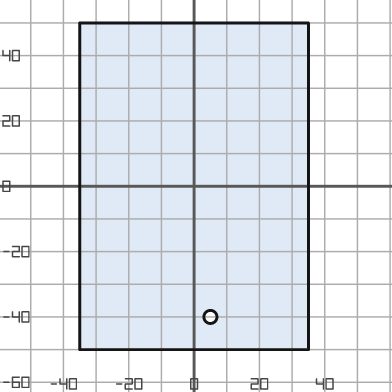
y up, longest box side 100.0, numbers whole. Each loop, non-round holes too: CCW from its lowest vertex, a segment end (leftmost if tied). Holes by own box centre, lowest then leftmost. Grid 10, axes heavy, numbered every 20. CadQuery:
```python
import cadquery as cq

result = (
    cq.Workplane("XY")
    .moveTo(-35.0, -50.0)
    .lineTo(35.0, -50.0)
    .lineTo(35.0, 50.0)
    .lineTo(-35.0, 50.0)
    .close()
    .moveTo(5.0, -40.0)
    .circle(2.0)
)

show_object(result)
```